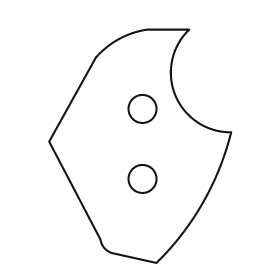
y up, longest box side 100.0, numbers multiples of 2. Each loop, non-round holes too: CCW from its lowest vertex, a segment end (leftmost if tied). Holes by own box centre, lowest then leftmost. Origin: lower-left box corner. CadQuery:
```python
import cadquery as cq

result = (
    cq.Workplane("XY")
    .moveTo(46.0, 0.0)
    .threePointArc((66.0, 26.0), (78.0, 56.0))
    .threePointArc((54.0, 72.0), (60.0, 100.0))
    .lineTo(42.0, 100.0)
    .threePointArc((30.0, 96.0), (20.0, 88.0))
    .lineTo(0.0, 52.0)
    .lineTo(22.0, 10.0)
    .threePointArc((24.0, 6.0), (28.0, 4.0))
    .close()
    .moveTo(40.0, 36.0)
    .circle(6.0)
    .moveTo(40.0, 66.0)
    .circle(6.0)
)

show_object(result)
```